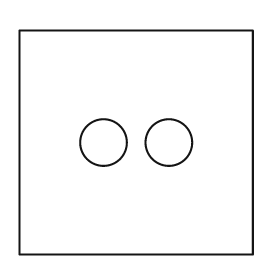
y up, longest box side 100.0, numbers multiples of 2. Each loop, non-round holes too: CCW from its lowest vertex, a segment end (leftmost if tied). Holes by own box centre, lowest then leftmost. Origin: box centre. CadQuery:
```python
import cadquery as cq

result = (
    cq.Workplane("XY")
    .moveTo(-50.0, -48.0)
    .lineTo(50.0, -48.0)
    .lineTo(50.0, 48.0)
    .lineTo(-50.0, 48.0)
    .close()
    .moveTo(-14.0, 0.0)
    .circle(10.0)
    .moveTo(14.0, 0.0)
    .circle(10.0)
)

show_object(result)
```